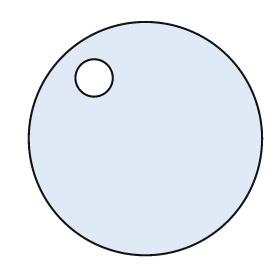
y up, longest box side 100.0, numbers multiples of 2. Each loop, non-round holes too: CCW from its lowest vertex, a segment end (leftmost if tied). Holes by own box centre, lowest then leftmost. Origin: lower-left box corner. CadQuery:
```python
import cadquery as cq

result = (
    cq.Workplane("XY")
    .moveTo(50.0, 50.0)
    .circle(50.0)
    .moveTo(28.0, 76.0)
    .circle(8.0)
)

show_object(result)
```